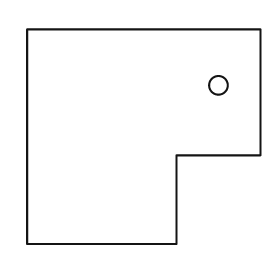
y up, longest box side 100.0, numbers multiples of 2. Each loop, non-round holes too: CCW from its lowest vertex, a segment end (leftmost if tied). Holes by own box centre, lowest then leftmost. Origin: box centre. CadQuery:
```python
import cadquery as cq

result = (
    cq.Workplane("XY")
    .moveTo(-50.0, -46.0)
    .lineTo(14.0, -46.0)
    .lineTo(14.0, -8.0)
    .lineTo(50.0, -8.0)
    .lineTo(50.0, 46.0)
    .lineTo(-50.0, 46.0)
    .close()
    .moveTo(32.0, 22.0)
    .circle(4.0)
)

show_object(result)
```